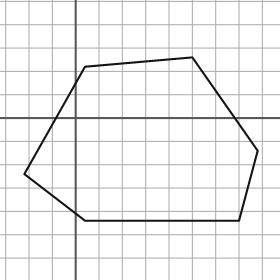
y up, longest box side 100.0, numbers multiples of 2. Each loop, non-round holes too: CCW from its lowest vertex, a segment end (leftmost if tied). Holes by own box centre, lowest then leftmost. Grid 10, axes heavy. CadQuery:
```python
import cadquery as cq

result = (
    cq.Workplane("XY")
    .moveTo(4.0, -44.0)
    .lineTo(70.0, -44.0)
    .lineTo(78.0, -14.0)
    .lineTo(50.0, 26.0)
    .lineTo(4.0, 22.0)
    .lineTo(-22.0, -24.0)
    .close()
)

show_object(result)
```